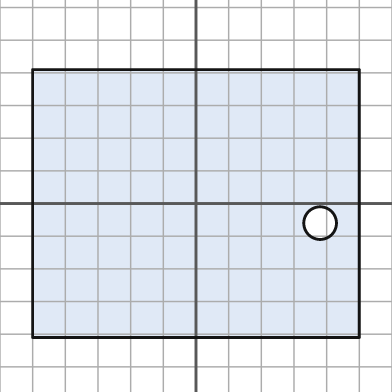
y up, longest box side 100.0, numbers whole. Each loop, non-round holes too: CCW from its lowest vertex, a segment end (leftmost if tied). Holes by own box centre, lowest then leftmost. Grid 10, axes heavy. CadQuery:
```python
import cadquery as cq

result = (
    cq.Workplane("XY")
    .moveTo(-50.0, -41.0)
    .lineTo(50.0, -41.0)
    .lineTo(50.0, 41.0)
    .lineTo(-50.0, 41.0)
    .close()
    .moveTo(38.0, -6.0)
    .circle(5.0)
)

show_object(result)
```